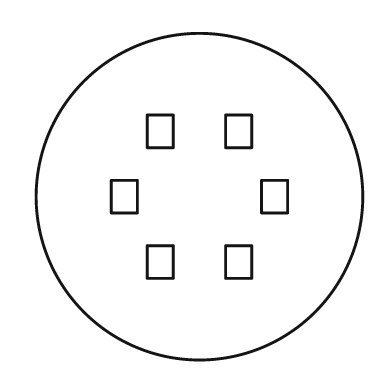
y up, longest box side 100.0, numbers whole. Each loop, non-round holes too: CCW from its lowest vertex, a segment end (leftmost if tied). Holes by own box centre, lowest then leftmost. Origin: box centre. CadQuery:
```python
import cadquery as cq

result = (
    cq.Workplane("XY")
    .moveTo(0.0, 0.0)
    .circle(50.0)
    .moveTo(-16.0, -25.0)
    .lineTo(-8.0, -25.0)
    .lineTo(-8.0, -15.0)
    .lineTo(-16.0, -15.0)
    .close()
    .moveTo(8.0, -25.0)
    .lineTo(16.0, -25.0)
    .lineTo(16.0, -15.0)
    .lineTo(8.0, -15.0)
    .close()
    .moveTo(-27.0, -5.0)
    .lineTo(-19.0, -5.0)
    .lineTo(-19.0, 5.0)
    .lineTo(-27.0, 5.0)
    .close()
    .moveTo(19.0, -5.0)
    .lineTo(27.0, -5.0)
    .lineTo(27.0, 5.0)
    .lineTo(19.0, 5.0)
    .close()
    .moveTo(-16.0, 15.0)
    .lineTo(-8.0, 15.0)
    .lineTo(-8.0, 25.0)
    .lineTo(-16.0, 25.0)
    .close()
    .moveTo(8.0, 15.0)
    .lineTo(16.0, 15.0)
    .lineTo(16.0, 25.0)
    .lineTo(8.0, 25.0)
    .close()
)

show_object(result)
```